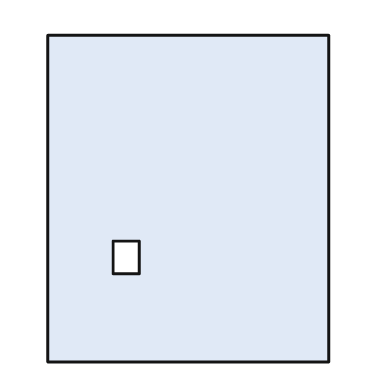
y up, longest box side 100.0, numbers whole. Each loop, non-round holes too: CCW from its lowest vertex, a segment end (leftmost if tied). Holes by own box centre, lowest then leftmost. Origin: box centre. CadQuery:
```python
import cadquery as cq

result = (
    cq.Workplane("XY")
    .moveTo(-43.0, -50.0)
    .lineTo(43.0, -50.0)
    .lineTo(43.0, 50.0)
    .lineTo(-43.0, 50.0)
    .close()
    .moveTo(-23.0, -23.0)
    .lineTo(-15.0, -23.0)
    .lineTo(-15.0, -13.0)
    .lineTo(-23.0, -13.0)
    .close()
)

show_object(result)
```